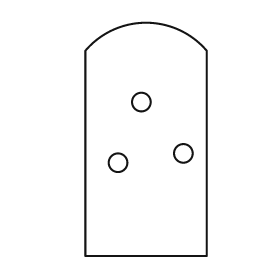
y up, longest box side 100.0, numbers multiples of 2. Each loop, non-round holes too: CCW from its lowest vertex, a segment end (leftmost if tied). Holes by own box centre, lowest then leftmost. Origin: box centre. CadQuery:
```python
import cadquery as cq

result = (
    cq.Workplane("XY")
    .moveTo(-26.0, -50.0)
    .lineTo(26.0, -50.0)
    .lineTo(26.0, 38.0)
    .threePointArc((0.0, 50.0), (-26.0, 38.0))
    .close()
    .moveTo(-12.0, -10.0)
    .circle(4.0)
    .moveTo(16.0, -6.0)
    .circle(4.0)
    .moveTo(-2.0, 16.0)
    .circle(4.0)
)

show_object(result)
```